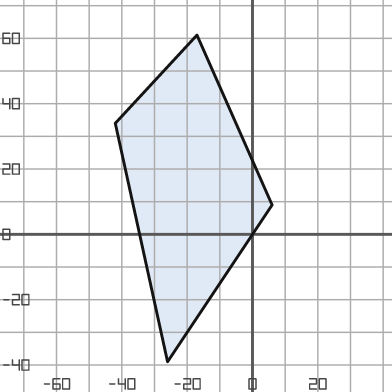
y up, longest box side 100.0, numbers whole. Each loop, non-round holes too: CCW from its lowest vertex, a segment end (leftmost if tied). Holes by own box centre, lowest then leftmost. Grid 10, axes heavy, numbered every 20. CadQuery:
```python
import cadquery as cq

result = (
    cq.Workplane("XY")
    .moveTo(-26.0, -39.0)
    .lineTo(6.0, 9.0)
    .lineTo(-17.0, 61.0)
    .lineTo(-42.0, 34.0)
    .close()
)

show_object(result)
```